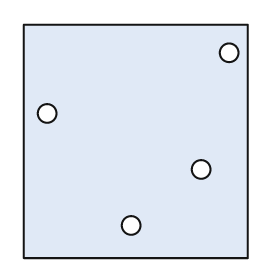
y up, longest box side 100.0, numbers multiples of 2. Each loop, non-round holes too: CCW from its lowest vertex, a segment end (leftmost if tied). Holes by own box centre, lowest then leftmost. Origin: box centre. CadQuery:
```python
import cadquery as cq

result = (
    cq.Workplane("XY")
    .moveTo(-48.0, -50.0)
    .lineTo(48.0, -50.0)
    .lineTo(48.0, 50.0)
    .lineTo(-48.0, 50.0)
    .close()
    .moveTo(-2.0, -36.0)
    .circle(4.0)
    .moveTo(28.0, -12.0)
    .circle(4.0)
    .moveTo(-38.0, 12.0)
    .circle(4.0)
    .moveTo(40.0, 38.0)
    .circle(4.0)
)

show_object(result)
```